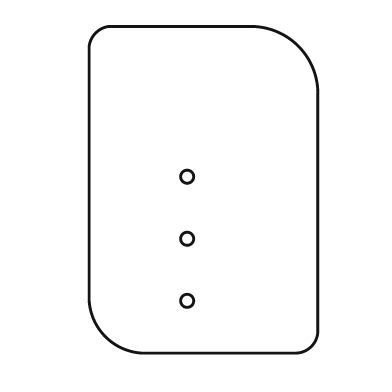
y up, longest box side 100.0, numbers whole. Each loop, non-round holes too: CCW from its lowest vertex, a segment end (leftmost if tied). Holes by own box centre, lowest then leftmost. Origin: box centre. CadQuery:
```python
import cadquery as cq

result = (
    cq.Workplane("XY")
    .moveTo(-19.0, -50.0)
    .lineTo(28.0, -50.0)
    .threePointArc((33.0, -48.0), (35.0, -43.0))
    .lineTo(35.0, 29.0)
    .threePointArc((29.0, 44.0), (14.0, 50.0))
    .lineTo(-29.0, 50.0)
    .threePointArc((-33.0, 48.0), (-35.0, 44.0))
    .lineTo(-35.0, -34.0)
    .threePointArc((-30.0, -45.0), (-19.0, -50.0))
    .close()
    .moveTo(-5.0, -34.0)
    .circle(2.0)
    .moveTo(-5.0, -15.0)
    .circle(2.0)
    .moveTo(-5.0, 4.0)
    .circle(2.0)
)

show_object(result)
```